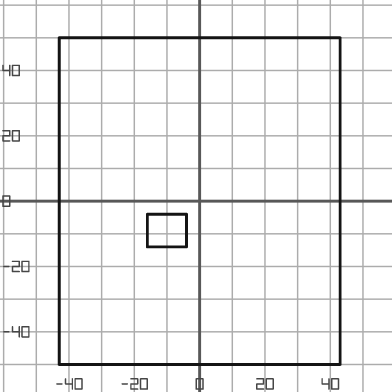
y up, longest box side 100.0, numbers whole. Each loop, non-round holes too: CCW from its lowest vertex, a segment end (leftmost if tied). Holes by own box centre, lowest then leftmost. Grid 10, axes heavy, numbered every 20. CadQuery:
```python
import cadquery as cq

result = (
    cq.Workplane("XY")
    .moveTo(-43.0, -50.0)
    .lineTo(43.0, -50.0)
    .lineTo(43.0, 50.0)
    .lineTo(-43.0, 50.0)
    .close()
    .moveTo(-16.0, -14.0)
    .lineTo(-4.0, -14.0)
    .lineTo(-4.0, -4.0)
    .lineTo(-16.0, -4.0)
    .close()
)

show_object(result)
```